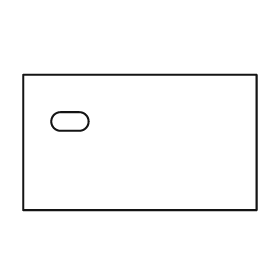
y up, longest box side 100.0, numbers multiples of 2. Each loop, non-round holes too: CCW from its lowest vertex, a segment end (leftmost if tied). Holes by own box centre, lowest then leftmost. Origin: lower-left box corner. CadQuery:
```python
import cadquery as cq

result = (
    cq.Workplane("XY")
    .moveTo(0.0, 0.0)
    .lineTo(100.0, 0.0)
    .lineTo(100.0, 58.0)
    .lineTo(0.0, 58.0)
    .close()
    .moveTo(16.0, 34.0)
    .lineTo(24.0, 34.0)
    .threePointArc((28.0, 38.0), (24.0, 42.0))
    .lineTo(16.0, 42.0)
    .threePointArc((12.0, 38.0), (16.0, 34.0))
    .close()
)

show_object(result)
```